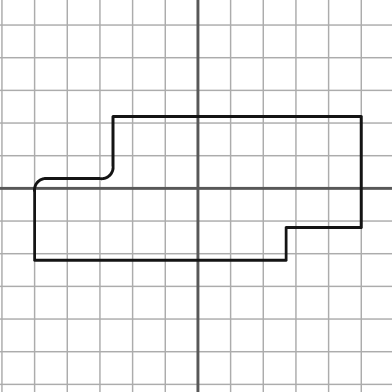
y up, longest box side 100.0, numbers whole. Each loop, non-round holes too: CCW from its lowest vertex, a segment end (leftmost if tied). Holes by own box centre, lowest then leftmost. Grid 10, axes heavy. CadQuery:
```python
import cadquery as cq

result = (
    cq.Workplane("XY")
    .moveTo(-50.0, -22.0)
    .lineTo(27.0, -22.0)
    .lineTo(27.0, -12.0)
    .lineTo(50.0, -12.0)
    .lineTo(50.0, 22.0)
    .lineTo(-26.0, 22.0)
    .lineTo(-26.0, 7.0)
    .threePointArc((-27.0, 4.0), (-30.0, 3.0))
    .lineTo(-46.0, 3.0)
    .threePointArc((-49.0, 2.0), (-50.0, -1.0))
    .close()
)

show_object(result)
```